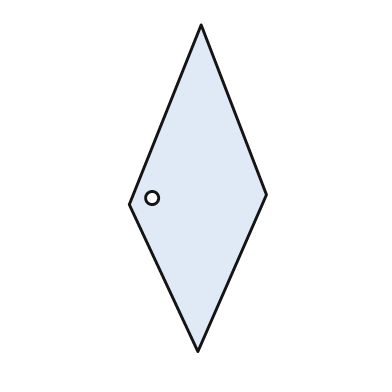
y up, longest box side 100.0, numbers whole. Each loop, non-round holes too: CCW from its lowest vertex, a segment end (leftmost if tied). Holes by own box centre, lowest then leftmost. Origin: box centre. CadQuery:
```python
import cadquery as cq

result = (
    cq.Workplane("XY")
    .moveTo(0.0, -50.0)
    .lineTo(21.0, -2.0)
    .lineTo(1.0, 50.0)
    .lineTo(-21.0, -5.0)
    .close()
    .moveTo(-14.0, -3.0)
    .circle(2.0)
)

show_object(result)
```